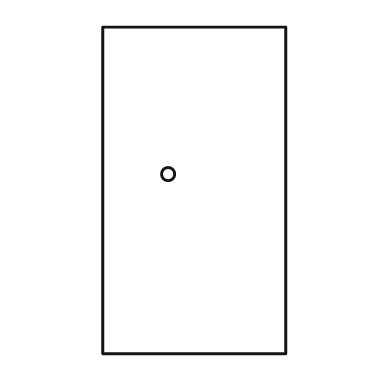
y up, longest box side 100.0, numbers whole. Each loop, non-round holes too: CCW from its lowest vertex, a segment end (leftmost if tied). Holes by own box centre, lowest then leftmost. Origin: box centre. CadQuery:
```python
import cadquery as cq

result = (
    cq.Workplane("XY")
    .moveTo(-28.0, -50.0)
    .lineTo(28.0, -50.0)
    .lineTo(28.0, 50.0)
    .lineTo(-28.0, 50.0)
    .close()
    .moveTo(-8.0, 5.0)
    .circle(2.0)
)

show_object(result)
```